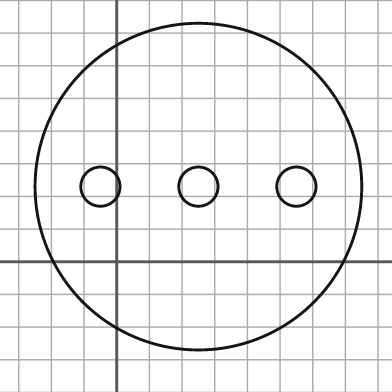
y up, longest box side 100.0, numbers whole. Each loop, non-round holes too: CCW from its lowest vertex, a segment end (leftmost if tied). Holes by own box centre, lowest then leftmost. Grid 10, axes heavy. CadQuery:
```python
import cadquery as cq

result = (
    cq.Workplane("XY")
    .moveTo(25.0, 23.0)
    .circle(50.0)
    .moveTo(-5.0, 23.0)
    .circle(6.0)
    .moveTo(25.0, 23.0)
    .circle(6.0)
    .moveTo(55.0, 23.0)
    .circle(6.0)
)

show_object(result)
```